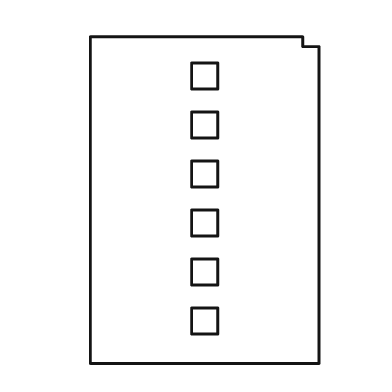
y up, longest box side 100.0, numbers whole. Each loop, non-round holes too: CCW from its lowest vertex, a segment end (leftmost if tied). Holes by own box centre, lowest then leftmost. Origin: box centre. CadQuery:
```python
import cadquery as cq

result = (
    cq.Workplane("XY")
    .moveTo(-35.0, -50.0)
    .lineTo(35.0, -50.0)
    .lineTo(35.0, 47.0)
    .lineTo(30.0, 47.0)
    .lineTo(30.0, 50.0)
    .lineTo(-35.0, 50.0)
    .close()
    .moveTo(-4.0, -41.0)
    .lineTo(4.0, -41.0)
    .lineTo(4.0, -33.0)
    .lineTo(-4.0, -33.0)
    .close()
    .moveTo(-4.0, -26.0)
    .lineTo(4.0, -26.0)
    .lineTo(4.0, -18.0)
    .lineTo(-4.0, -18.0)
    .close()
    .moveTo(-4.0, -11.0)
    .lineTo(4.0, -11.0)
    .lineTo(4.0, -3.0)
    .lineTo(-4.0, -3.0)
    .close()
    .moveTo(-4.0, 4.0)
    .lineTo(4.0, 4.0)
    .lineTo(4.0, 12.0)
    .lineTo(-4.0, 12.0)
    .close()
    .moveTo(-4.0, 19.0)
    .lineTo(4.0, 19.0)
    .lineTo(4.0, 27.0)
    .lineTo(-4.0, 27.0)
    .close()
    .moveTo(-4.0, 34.0)
    .lineTo(4.0, 34.0)
    .lineTo(4.0, 42.0)
    .lineTo(-4.0, 42.0)
    .close()
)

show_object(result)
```